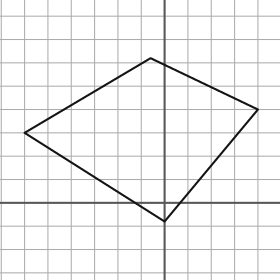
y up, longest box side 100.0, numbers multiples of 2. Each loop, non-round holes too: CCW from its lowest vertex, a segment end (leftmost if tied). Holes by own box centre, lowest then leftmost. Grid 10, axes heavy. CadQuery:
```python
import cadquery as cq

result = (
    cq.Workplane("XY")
    .moveTo(0.0, -8.0)
    .lineTo(40.0, 40.0)
    .lineTo(-6.0, 62.0)
    .lineTo(-60.0, 30.0)
    .close()
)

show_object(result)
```